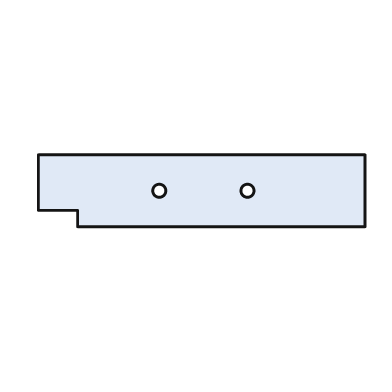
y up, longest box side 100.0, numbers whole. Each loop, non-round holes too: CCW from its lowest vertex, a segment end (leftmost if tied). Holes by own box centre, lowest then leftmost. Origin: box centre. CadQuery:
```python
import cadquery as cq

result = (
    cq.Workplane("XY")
    .moveTo(-38.0, -11.0)
    .lineTo(50.0, -11.0)
    .lineTo(50.0, 11.0)
    .lineTo(-50.0, 11.0)
    .lineTo(-50.0, -6.0)
    .lineTo(-38.0, -6.0)
    .close()
    .moveTo(-13.0, 0.0)
    .circle(2.0)
    .moveTo(14.0, 0.0)
    .circle(2.0)
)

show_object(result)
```